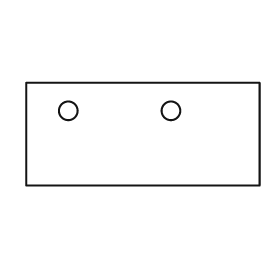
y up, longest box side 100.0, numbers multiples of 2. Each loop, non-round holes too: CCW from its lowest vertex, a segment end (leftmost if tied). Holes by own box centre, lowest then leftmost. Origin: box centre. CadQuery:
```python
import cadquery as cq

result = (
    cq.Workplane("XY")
    .moveTo(-50.0, -22.0)
    .lineTo(50.0, -22.0)
    .lineTo(50.0, 22.0)
    .lineTo(-50.0, 22.0)
    .close()
    .moveTo(-32.0, 10.0)
    .circle(4.0)
    .moveTo(12.0, 10.0)
    .circle(4.0)
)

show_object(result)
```